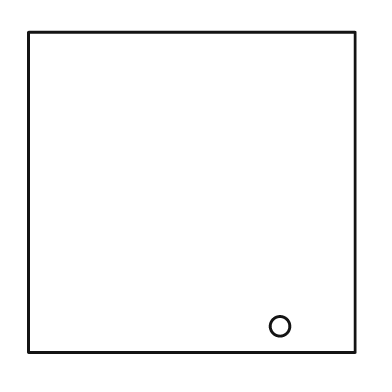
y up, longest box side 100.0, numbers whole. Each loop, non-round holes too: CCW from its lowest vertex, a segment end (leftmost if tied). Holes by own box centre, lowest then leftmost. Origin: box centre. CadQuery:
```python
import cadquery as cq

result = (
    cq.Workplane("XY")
    .moveTo(-50.0, -49.0)
    .lineTo(50.0, -49.0)
    .lineTo(50.0, 49.0)
    .lineTo(-50.0, 49.0)
    .close()
    .moveTo(27.0, -41.0)
    .circle(3.0)
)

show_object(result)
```